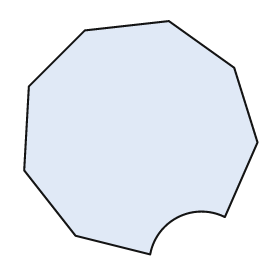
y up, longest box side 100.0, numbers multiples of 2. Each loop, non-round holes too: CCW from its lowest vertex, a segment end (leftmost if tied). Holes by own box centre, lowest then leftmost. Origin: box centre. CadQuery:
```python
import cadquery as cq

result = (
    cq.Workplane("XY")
    .moveTo(4.0, -50.0)
    .threePointArc((16.0, -34.0), (36.0, -34.0))
    .lineTo(50.0, -2.0)
    .lineTo(40.0, 30.0)
    .lineTo(12.0, 50.0)
    .lineTo(-24.0, 46.0)
    .lineTo(-48.0, 22.0)
    .lineTo(-50.0, -14.0)
    .lineTo(-28.0, -42.0)
    .close()
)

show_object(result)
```